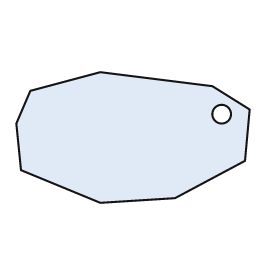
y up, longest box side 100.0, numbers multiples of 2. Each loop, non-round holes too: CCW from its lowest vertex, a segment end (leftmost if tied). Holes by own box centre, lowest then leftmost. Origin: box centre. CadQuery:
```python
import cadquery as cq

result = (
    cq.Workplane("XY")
    .moveTo(-14.0, -28.0)
    .lineTo(18.0, -26.0)
    .lineTo(48.0, -10.0)
    .lineTo(50.0, 12.0)
    .lineTo(34.0, 22.0)
    .lineTo(-14.0, 28.0)
    .lineTo(-44.0, 20.0)
    .lineTo(-50.0, 6.0)
    .lineTo(-48.0, -14.0)
    .close()
    .moveTo(38.0, 10.0)
    .circle(4.0)
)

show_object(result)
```